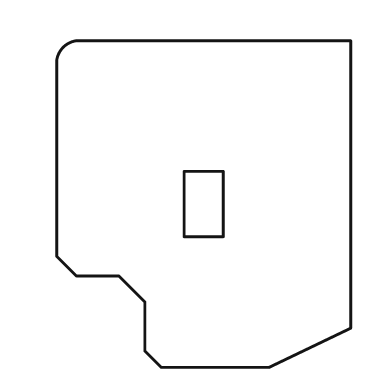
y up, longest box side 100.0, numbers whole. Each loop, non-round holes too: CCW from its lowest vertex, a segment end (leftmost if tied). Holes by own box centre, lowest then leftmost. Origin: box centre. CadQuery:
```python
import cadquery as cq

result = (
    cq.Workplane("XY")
    .moveTo(-13.0, -50.0)
    .lineTo(20.0, -50.0)
    .lineTo(45.0, -38.0)
    .lineTo(45.0, 50.0)
    .lineTo(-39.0, 50.0)
    .threePointArc((-43.0, 48.0), (-45.0, 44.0))
    .lineTo(-45.0, -16.0)
    .lineTo(-39.0, -22.0)
    .lineTo(-26.0, -22.0)
    .lineTo(-18.0, -30.0)
    .lineTo(-18.0, -45.0)
    .close()
    .moveTo(-6.0, -10.0)
    .lineTo(6.0, -10.0)
    .lineTo(6.0, 10.0)
    .lineTo(-6.0, 10.0)
    .close()
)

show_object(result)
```